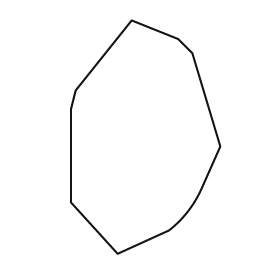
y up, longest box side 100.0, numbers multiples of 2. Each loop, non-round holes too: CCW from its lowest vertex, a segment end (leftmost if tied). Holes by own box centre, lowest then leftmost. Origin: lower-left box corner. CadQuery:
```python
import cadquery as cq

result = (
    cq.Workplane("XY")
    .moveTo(20.0, 0.0)
    .lineTo(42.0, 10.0)
    .threePointArc((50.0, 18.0), (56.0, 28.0))
    .lineTo(64.0, 46.0)
    .lineTo(52.0, 86.0)
    .lineTo(46.0, 92.0)
    .lineTo(26.0, 100.0)
    .lineTo(2.0, 70.0)
    .lineTo(0.0, 62.0)
    .lineTo(0.0, 22.0)
    .close()
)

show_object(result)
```